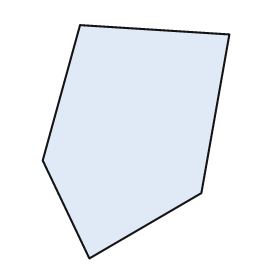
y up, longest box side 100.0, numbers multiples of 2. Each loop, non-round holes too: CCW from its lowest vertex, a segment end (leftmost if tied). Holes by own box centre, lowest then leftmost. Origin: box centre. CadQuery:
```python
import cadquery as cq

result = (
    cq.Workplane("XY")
    .moveTo(-20.0, -50.0)
    .lineTo(28.0, -22.0)
    .lineTo(40.0, 46.0)
    .lineTo(-24.0, 50.0)
    .lineTo(-40.0, -8.0)
    .close()
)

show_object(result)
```